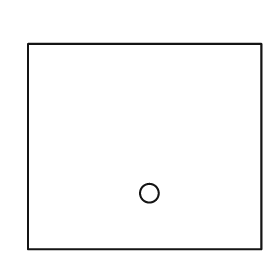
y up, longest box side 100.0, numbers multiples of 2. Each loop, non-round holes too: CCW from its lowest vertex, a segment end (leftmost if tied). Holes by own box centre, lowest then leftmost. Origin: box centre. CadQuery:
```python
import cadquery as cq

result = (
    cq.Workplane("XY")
    .moveTo(-50.0, -44.0)
    .lineTo(50.0, -44.0)
    .lineTo(50.0, 44.0)
    .lineTo(-50.0, 44.0)
    .close()
    .moveTo(2.0, -20.0)
    .circle(4.0)
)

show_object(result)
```